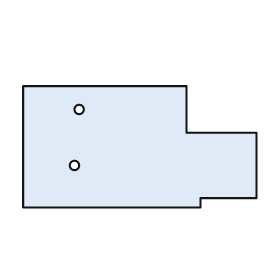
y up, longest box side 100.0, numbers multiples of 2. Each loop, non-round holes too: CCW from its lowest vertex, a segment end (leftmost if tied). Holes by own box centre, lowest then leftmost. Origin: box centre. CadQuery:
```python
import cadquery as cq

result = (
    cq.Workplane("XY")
    .moveTo(-50.0, -26.0)
    .lineTo(26.0, -26.0)
    .lineTo(26.0, -22.0)
    .lineTo(50.0, -22.0)
    .lineTo(50.0, 6.0)
    .lineTo(20.0, 6.0)
    .lineTo(20.0, 26.0)
    .lineTo(-50.0, 26.0)
    .close()
    .moveTo(-28.0, -8.0)
    .circle(2.0)
    .moveTo(-26.0, 16.0)
    .circle(2.0)
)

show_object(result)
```